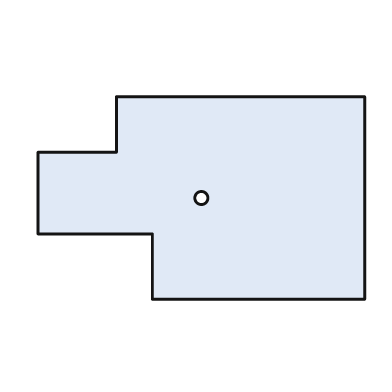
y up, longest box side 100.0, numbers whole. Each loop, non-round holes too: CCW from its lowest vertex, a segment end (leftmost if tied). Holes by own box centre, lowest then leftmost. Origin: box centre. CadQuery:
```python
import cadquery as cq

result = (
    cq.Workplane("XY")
    .moveTo(-15.0, -31.0)
    .lineTo(50.0, -31.0)
    .lineTo(50.0, 31.0)
    .lineTo(-26.0, 31.0)
    .lineTo(-26.0, 14.0)
    .lineTo(-50.0, 14.0)
    .lineTo(-50.0, -11.0)
    .lineTo(-15.0, -11.0)
    .close()
    .moveTo(0.0, 0.0)
    .circle(2.0)
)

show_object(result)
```